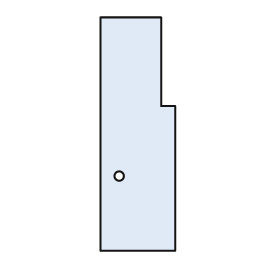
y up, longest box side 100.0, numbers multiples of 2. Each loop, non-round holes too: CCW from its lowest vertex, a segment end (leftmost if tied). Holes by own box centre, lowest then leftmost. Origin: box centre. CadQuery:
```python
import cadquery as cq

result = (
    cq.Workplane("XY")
    .moveTo(-16.0, -50.0)
    .lineTo(16.0, -50.0)
    .lineTo(16.0, 12.0)
    .lineTo(10.0, 12.0)
    .lineTo(10.0, 50.0)
    .lineTo(-16.0, 50.0)
    .close()
    .moveTo(-8.0, -18.0)
    .circle(2.0)
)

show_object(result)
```